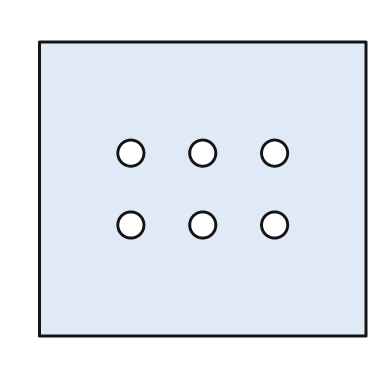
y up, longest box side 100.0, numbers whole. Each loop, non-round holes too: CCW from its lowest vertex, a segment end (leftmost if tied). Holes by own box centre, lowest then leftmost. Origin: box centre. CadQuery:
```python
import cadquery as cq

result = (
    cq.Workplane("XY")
    .moveTo(-50.0, -45.0)
    .lineTo(50.0, -45.0)
    .lineTo(50.0, 45.0)
    .lineTo(-50.0, 45.0)
    .close()
    .moveTo(-22.0, -11.0)
    .circle(4.0)
    .moveTo(0.0, -11.0)
    .circle(4.0)
    .moveTo(22.0, -11.0)
    .circle(4.0)
    .moveTo(-22.0, 11.0)
    .circle(4.0)
    .moveTo(0.0, 11.0)
    .circle(4.0)
    .moveTo(22.0, 11.0)
    .circle(4.0)
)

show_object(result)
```